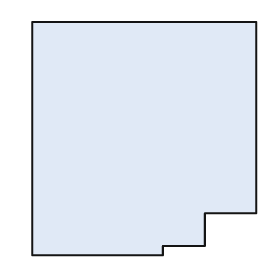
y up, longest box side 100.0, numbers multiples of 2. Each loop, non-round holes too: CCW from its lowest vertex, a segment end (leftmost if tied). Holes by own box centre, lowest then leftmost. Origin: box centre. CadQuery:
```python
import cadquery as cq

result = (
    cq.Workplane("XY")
    .moveTo(-48.0, -50.0)
    .lineTo(8.0, -50.0)
    .lineTo(8.0, -46.0)
    .lineTo(26.0, -46.0)
    .lineTo(26.0, -32.0)
    .lineTo(48.0, -32.0)
    .lineTo(48.0, 50.0)
    .lineTo(-48.0, 50.0)
    .close()
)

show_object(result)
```